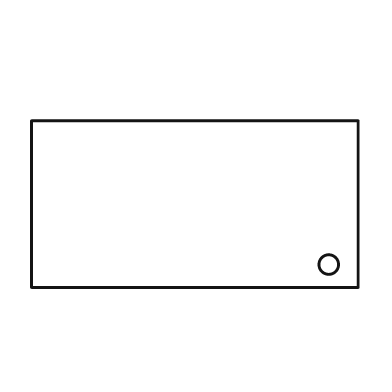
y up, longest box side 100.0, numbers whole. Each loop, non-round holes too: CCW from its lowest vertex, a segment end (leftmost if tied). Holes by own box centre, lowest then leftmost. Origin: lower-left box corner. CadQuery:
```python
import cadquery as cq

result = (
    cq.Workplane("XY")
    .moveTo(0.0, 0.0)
    .lineTo(100.0, 0.0)
    .lineTo(100.0, 51.0)
    .lineTo(0.0, 51.0)
    .close()
    .moveTo(91.0, 7.0)
    .circle(3.0)
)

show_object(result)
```